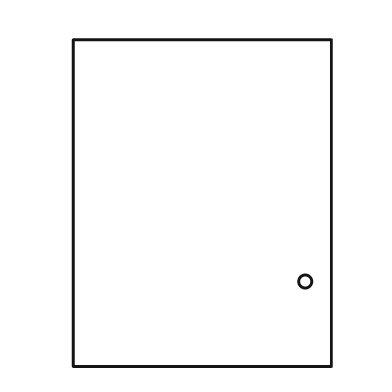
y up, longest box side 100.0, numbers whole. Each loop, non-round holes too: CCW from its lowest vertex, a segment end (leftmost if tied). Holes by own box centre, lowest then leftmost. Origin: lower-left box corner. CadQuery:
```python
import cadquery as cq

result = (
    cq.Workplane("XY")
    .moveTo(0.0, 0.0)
    .lineTo(79.0, 0.0)
    .lineTo(79.0, 100.0)
    .lineTo(0.0, 100.0)
    .close()
    .moveTo(71.0, 26.0)
    .circle(2.0)
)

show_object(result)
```